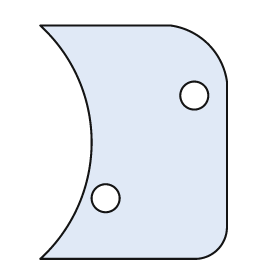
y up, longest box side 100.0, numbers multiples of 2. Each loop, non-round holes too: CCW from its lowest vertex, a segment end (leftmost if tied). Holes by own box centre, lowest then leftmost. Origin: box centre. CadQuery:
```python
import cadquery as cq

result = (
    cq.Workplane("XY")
    .moveTo(-40.0, -50.0)
    .lineTo(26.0, -50.0)
    .threePointArc((36.0, -46.0), (40.0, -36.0))
    .lineTo(40.0, 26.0)
    .threePointArc((32.0, 42.0), (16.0, 50.0))
    .lineTo(-40.0, 50.0)
    .threePointArc((-18.0, 0.0), (-40.0, -50.0))
    .close()
    .moveTo(-12.0, -24.0)
    .circle(6.0)
    .moveTo(26.0, 20.0)
    .circle(6.0)
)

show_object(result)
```